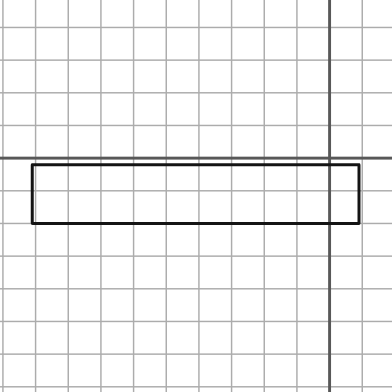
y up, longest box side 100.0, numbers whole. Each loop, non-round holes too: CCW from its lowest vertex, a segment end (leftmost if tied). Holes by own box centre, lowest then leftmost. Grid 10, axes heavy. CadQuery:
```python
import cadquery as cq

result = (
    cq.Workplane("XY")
    .moveTo(-91.0, -20.0)
    .lineTo(9.0, -20.0)
    .lineTo(9.0, -2.0)
    .lineTo(-91.0, -2.0)
    .close()
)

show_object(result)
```